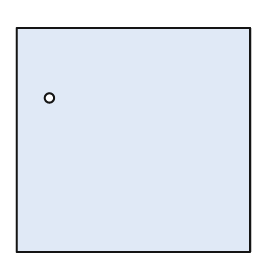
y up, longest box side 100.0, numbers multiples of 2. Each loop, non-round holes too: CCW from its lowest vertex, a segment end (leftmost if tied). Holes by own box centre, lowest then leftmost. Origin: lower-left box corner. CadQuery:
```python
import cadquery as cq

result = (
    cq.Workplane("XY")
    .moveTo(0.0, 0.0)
    .lineTo(100.0, 0.0)
    .lineTo(100.0, 96.0)
    .lineTo(0.0, 96.0)
    .close()
    .moveTo(14.0, 66.0)
    .circle(2.0)
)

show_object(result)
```